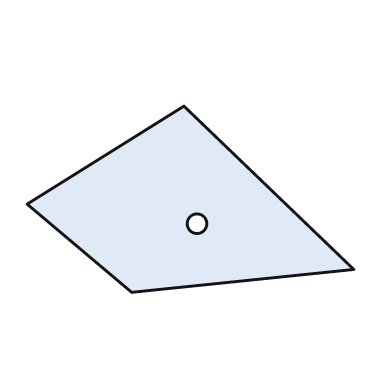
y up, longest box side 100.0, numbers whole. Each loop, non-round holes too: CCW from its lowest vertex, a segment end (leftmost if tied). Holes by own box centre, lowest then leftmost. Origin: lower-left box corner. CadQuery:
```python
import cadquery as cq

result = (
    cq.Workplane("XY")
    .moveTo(32.0, 0.0)
    .lineTo(100.0, 7.0)
    .lineTo(48.0, 57.0)
    .lineTo(0.0, 27.0)
    .close()
    .moveTo(52.0, 21.0)
    .circle(3.0)
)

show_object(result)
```